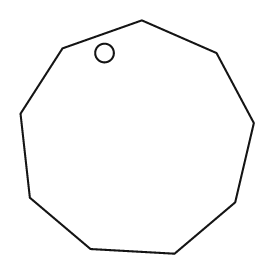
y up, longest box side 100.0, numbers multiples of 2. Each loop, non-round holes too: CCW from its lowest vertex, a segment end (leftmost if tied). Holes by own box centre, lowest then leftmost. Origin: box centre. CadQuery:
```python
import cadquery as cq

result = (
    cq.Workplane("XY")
    .moveTo(16.0, -50.0)
    .lineTo(42.0, -28.0)
    .lineTo(50.0, 6.0)
    .lineTo(34.0, 36.0)
    .lineTo(2.0, 50.0)
    .lineTo(-32.0, 38.0)
    .lineTo(-50.0, 10.0)
    .lineTo(-46.0, -26.0)
    .lineTo(-20.0, -48.0)
    .close()
    .moveTo(-14.0, 36.0)
    .circle(4.0)
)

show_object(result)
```